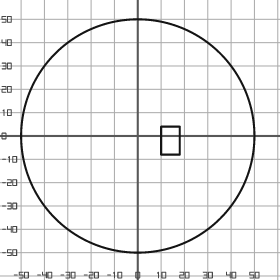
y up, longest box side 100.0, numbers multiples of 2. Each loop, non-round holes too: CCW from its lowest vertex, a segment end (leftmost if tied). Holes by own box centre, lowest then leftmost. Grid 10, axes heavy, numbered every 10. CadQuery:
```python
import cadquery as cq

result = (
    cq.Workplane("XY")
    .moveTo(0.0, 0.0)
    .circle(50.0)
    .moveTo(10.0, -8.0)
    .lineTo(18.0, -8.0)
    .lineTo(18.0, 4.0)
    .lineTo(10.0, 4.0)
    .close()
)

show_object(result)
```